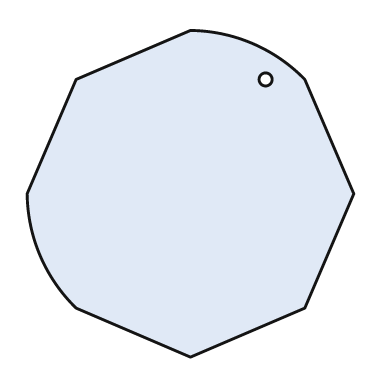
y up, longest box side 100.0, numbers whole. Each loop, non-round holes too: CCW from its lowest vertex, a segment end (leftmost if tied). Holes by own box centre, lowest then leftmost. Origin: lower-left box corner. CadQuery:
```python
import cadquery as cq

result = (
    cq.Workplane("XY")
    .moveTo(50.0, 0.0)
    .lineTo(85.0, 15.0)
    .lineTo(100.0, 50.0)
    .lineTo(85.0, 85.0)
    .threePointArc((69.0, 96.0), (50.0, 100.0))
    .lineTo(15.0, 85.0)
    .lineTo(0.0, 50.0)
    .threePointArc((4.0, 31.0), (15.0, 15.0))
    .close()
    .moveTo(73.0, 85.0)
    .circle(2.0)
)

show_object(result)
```